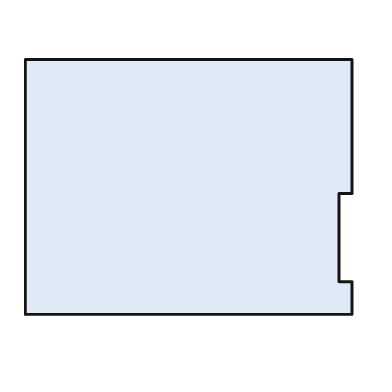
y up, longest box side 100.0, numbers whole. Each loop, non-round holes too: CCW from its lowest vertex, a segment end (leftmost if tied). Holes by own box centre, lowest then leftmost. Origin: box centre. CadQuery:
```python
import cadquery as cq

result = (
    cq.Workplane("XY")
    .moveTo(-50.0, -39.0)
    .lineTo(50.0, -39.0)
    .lineTo(50.0, -29.0)
    .lineTo(46.0, -29.0)
    .lineTo(46.0, -2.0)
    .lineTo(50.0, -2.0)
    .lineTo(50.0, 39.0)
    .lineTo(-50.0, 39.0)
    .close()
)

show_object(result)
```